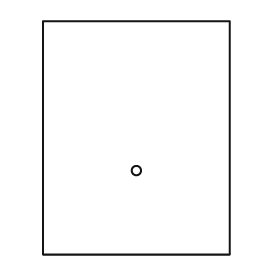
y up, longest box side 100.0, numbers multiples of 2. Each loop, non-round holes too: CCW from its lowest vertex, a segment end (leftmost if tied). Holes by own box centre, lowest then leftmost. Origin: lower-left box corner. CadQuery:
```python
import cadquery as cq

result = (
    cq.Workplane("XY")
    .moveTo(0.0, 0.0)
    .lineTo(80.0, 0.0)
    .lineTo(80.0, 100.0)
    .lineTo(0.0, 100.0)
    .close()
    .moveTo(40.0, 36.0)
    .circle(2.0)
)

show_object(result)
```